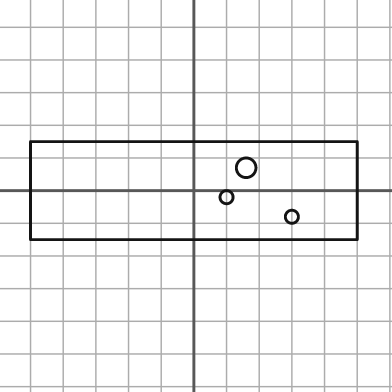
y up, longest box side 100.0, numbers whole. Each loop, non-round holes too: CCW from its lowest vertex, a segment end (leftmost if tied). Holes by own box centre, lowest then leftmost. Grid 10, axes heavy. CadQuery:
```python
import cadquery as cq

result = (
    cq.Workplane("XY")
    .moveTo(-50.0, -15.0)
    .lineTo(50.0, -15.0)
    .lineTo(50.0, 15.0)
    .lineTo(-50.0, 15.0)
    .close()
    .moveTo(30.0, -8.0)
    .circle(2.0)
    .moveTo(10.0, -2.0)
    .circle(2.0)
    .moveTo(16.0, 7.0)
    .circle(3.0)
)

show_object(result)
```